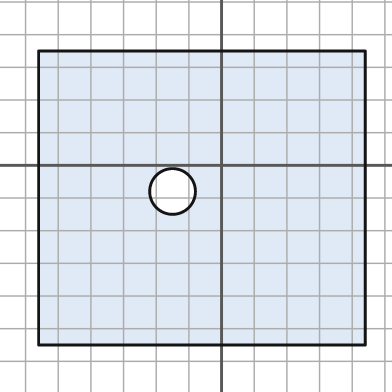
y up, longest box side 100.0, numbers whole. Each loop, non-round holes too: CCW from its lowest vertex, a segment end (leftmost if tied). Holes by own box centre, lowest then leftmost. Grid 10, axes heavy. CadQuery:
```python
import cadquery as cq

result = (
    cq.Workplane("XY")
    .moveTo(-56.0, -55.0)
    .lineTo(44.0, -55.0)
    .lineTo(44.0, 35.0)
    .lineTo(-56.0, 35.0)
    .close()
    .moveTo(-15.0, -8.0)
    .circle(7.0)
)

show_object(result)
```